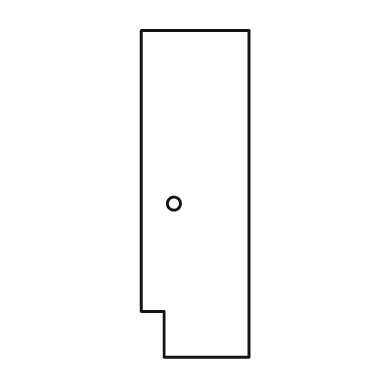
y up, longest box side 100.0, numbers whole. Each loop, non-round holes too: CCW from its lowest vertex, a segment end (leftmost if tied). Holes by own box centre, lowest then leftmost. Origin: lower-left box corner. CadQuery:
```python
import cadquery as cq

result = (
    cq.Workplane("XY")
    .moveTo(7.0, 0.0)
    .lineTo(33.0, 0.0)
    .lineTo(33.0, 100.0)
    .lineTo(0.0, 100.0)
    .lineTo(0.0, 14.0)
    .lineTo(7.0, 14.0)
    .close()
    .moveTo(10.0, 47.0)
    .circle(2.0)
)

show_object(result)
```